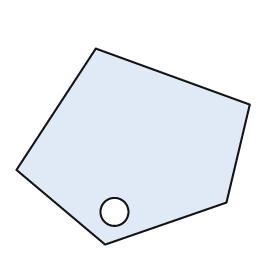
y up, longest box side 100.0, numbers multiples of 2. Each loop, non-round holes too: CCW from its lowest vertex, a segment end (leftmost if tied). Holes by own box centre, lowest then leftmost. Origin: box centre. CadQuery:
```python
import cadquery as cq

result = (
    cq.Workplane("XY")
    .moveTo(-12.0, -42.0)
    .lineTo(40.0, -24.0)
    .lineTo(50.0, 18.0)
    .lineTo(-16.0, 42.0)
    .lineTo(-50.0, -10.0)
    .close()
    .moveTo(-8.0, -28.0)
    .circle(6.0)
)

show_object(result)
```